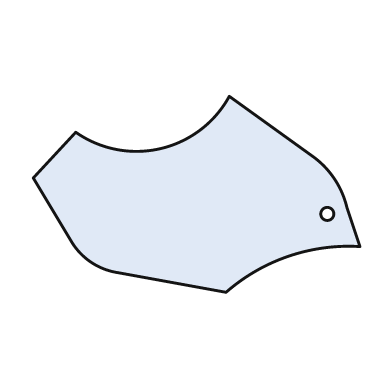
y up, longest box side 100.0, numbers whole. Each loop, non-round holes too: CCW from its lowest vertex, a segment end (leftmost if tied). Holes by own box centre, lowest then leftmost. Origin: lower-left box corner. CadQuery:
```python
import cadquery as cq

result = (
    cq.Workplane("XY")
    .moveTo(59.0, 0.0)
    .threePointArc((78.0, 11.0), (100.0, 14.0))
    .lineTo(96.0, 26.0)
    .threePointArc((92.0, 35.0), (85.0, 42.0))
    .lineTo(60.0, 60.0)
    .threePointArc((39.0, 44.0), (13.0, 49.0))
    .lineTo(0.0, 35.0)
    .lineTo(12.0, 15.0)
    .threePointArc((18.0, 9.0), (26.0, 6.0))
    .close()
    .moveTo(90.0, 24.0)
    .circle(2.0)
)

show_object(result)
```